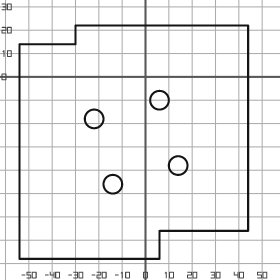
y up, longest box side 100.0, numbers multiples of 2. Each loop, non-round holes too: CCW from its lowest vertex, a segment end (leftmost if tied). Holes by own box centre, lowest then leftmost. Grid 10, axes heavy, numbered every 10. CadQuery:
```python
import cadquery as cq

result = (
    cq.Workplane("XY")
    .moveTo(-54.0, -78.0)
    .lineTo(6.0, -78.0)
    .lineTo(6.0, -66.0)
    .lineTo(44.0, -66.0)
    .lineTo(44.0, 22.0)
    .lineTo(-30.0, 22.0)
    .lineTo(-30.0, 14.0)
    .lineTo(-54.0, 14.0)
    .close()
    .moveTo(-14.0, -46.0)
    .circle(4.0)
    .moveTo(14.0, -38.0)
    .circle(4.0)
    .moveTo(-22.0, -18.0)
    .circle(4.0)
    .moveTo(6.0, -10.0)
    .circle(4.0)
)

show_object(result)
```